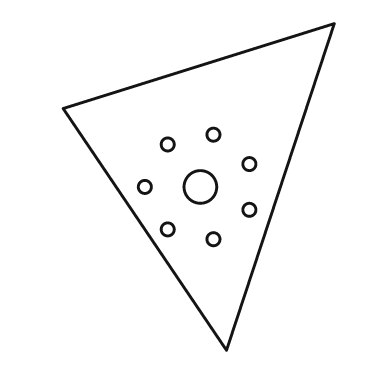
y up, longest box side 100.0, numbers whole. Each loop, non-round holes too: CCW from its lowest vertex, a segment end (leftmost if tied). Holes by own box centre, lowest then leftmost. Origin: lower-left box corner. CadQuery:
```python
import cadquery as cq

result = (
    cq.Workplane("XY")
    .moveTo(50.0, 0.0)
    .lineTo(83.0, 100.0)
    .lineTo(0.0, 74.0)
    .close()
    .moveTo(46.0, 34.0)
    .circle(2.0)
    .moveTo(32.0, 37.0)
    .circle(2.0)
    .moveTo(57.0, 43.0)
    .circle(2.0)
    .moveTo(25.0, 50.0)
    .circle(2.0)
    .moveTo(42.0, 50.0)
    .circle(5.0)
    .moveTo(57.0, 57.0)
    .circle(2.0)
    .moveTo(32.0, 63.0)
    .circle(2.0)
    .moveTo(46.0, 66.0)
    .circle(2.0)
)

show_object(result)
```